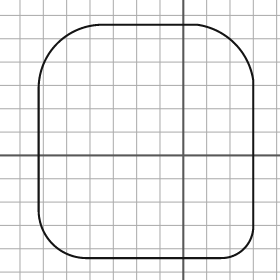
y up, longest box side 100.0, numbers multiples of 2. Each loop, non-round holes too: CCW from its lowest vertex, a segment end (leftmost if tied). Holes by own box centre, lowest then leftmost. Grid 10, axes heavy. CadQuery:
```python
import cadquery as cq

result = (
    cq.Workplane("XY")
    .moveTo(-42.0, -44.0)
    .lineTo(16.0, -44.0)
    .threePointArc((26.0, -40.0), (30.0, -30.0))
    .lineTo(30.0, 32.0)
    .threePointArc((22.0, 48.0), (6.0, 56.0))
    .lineTo(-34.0, 56.0)
    .threePointArc((-54.0, 48.0), (-62.0, 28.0))
    .lineTo(-62.0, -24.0)
    .threePointArc((-56.0, -38.0), (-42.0, -44.0))
    .close()
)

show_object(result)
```